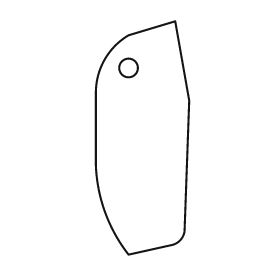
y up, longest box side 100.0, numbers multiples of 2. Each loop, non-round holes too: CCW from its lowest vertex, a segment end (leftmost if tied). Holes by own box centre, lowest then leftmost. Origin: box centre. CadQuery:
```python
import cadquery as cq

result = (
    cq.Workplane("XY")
    .moveTo(-6.0, -50.0)
    .lineTo(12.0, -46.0)
    .threePointArc((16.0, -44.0), (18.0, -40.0))
    .lineTo(20.0, 16.0)
    .lineTo(14.0, 50.0)
    .lineTo(-6.0, 44.0)
    .threePointArc((-16.0, 34.0), (-20.0, 20.0))
    .lineTo(-20.0, -12.0)
    .threePointArc((-16.0, -32.0), (-6.0, -50.0))
    .close()
    .moveTo(-6.0, 30.0)
    .circle(4.0)
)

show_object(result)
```